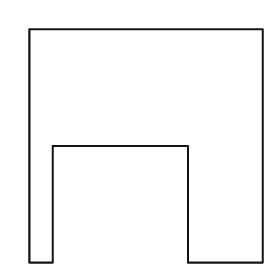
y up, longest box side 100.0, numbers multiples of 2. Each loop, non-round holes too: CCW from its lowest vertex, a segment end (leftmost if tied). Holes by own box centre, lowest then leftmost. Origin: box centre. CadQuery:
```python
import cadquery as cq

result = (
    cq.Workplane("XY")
    .moveTo(-50.0, -50.0)
    .lineTo(-40.0, -50.0)
    .lineTo(-40.0, 0.0)
    .lineTo(18.0, 0.0)
    .lineTo(18.0, -50.0)
    .lineTo(50.0, -50.0)
    .lineTo(50.0, 50.0)
    .lineTo(-50.0, 50.0)
    .close()
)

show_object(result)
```